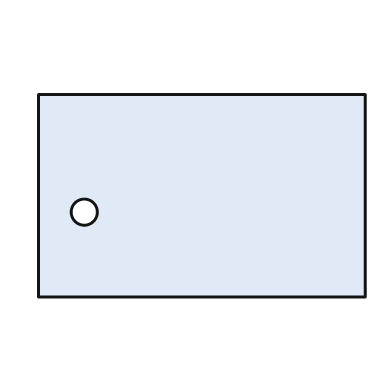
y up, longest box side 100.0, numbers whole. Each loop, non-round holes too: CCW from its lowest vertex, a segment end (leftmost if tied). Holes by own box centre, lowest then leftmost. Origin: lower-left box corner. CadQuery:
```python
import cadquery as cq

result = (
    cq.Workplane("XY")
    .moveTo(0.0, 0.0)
    .lineTo(100.0, 0.0)
    .lineTo(100.0, 62.0)
    .lineTo(0.0, 62.0)
    .close()
    .moveTo(14.0, 26.0)
    .circle(4.0)
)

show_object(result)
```